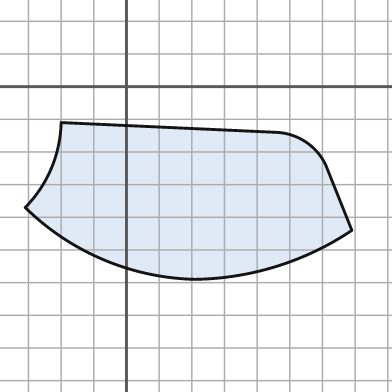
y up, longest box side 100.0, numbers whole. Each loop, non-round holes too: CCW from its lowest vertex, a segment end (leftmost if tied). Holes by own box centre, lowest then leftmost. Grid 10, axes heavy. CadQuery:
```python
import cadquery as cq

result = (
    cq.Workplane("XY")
    .moveTo(21.0, -59.0)
    .threePointArc((46.0, -55.0), (69.0, -44.0))
    .lineTo(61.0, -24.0)
    .threePointArc((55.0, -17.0), (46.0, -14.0))
    .lineTo(-20.0, -11.0)
    .threePointArc((-23.0, -25.0), (-31.0, -37.0))
    .threePointArc((-7.0, -53.0), (21.0, -59.0))
    .close()
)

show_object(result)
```